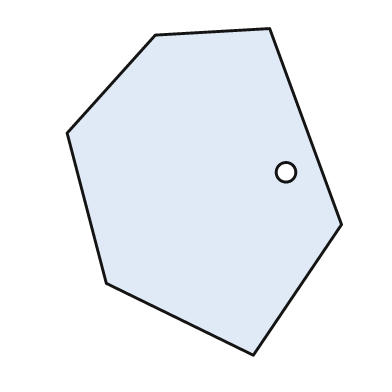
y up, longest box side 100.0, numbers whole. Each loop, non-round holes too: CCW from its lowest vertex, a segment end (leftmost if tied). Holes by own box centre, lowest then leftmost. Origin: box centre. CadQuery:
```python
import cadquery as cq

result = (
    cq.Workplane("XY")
    .moveTo(15.0, -50.0)
    .lineTo(42.0, -10.0)
    .lineTo(20.0, 50.0)
    .lineTo(-15.0, 48.0)
    .lineTo(-42.0, 18.0)
    .lineTo(-30.0, -28.0)
    .close()
    .moveTo(25.0, 6.0)
    .circle(3.0)
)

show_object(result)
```